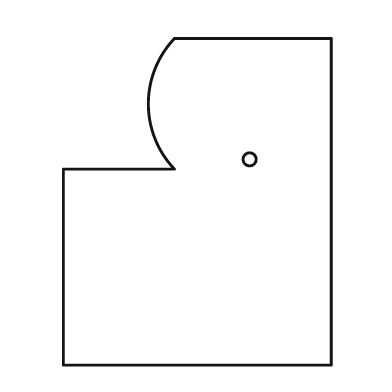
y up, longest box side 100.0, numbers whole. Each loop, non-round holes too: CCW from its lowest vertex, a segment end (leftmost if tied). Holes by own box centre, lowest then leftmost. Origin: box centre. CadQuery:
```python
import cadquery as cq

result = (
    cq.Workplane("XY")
    .moveTo(-41.0, -50.0)
    .lineTo(41.0, -50.0)
    .lineTo(41.0, 50.0)
    .lineTo(-7.0, 50.0)
    .threePointArc((-15.0, 30.0), (-7.0, 10.0))
    .lineTo(-41.0, 10.0)
    .close()
    .moveTo(16.0, 13.0)
    .circle(2.0)
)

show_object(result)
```